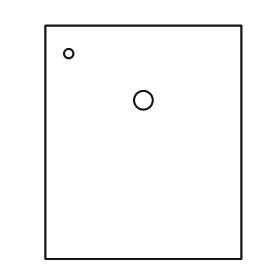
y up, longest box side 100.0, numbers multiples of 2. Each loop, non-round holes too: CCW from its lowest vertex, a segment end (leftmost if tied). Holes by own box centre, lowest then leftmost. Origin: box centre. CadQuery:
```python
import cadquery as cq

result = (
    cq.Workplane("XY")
    .moveTo(-42.0, -50.0)
    .lineTo(42.0, -50.0)
    .lineTo(42.0, 50.0)
    .lineTo(-42.0, 50.0)
    .close()
    .moveTo(0.0, 18.0)
    .circle(4.0)
    .moveTo(-32.0, 38.0)
    .circle(2.0)
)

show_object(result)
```